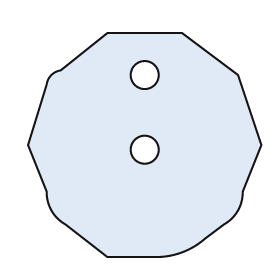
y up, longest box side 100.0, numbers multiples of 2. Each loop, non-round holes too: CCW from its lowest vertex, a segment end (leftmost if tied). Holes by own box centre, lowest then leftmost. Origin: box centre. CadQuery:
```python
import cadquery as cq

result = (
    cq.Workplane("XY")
    .moveTo(-16.0, -48.0)
    .lineTo(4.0, -48.0)
    .threePointArc((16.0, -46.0), (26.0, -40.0))
    .lineTo(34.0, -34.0)
    .threePointArc((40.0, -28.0), (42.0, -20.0))
    .lineTo(50.0, 0.0)
    .lineTo(40.0, 30.0)
    .lineTo(16.0, 48.0)
    .lineTo(-16.0, 48.0)
    .lineTo(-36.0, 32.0)
    .threePointArc((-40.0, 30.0), (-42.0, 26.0))
    .lineTo(-50.0, 0.0)
    .lineTo(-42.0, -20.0)
    .threePointArc((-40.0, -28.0), (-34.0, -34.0))
    .close()
    .moveTo(0.0, -2.0)
    .circle(6.0)
    .moveTo(0.0, 30.0)
    .circle(6.0)
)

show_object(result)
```